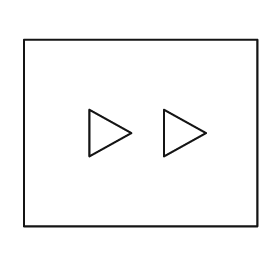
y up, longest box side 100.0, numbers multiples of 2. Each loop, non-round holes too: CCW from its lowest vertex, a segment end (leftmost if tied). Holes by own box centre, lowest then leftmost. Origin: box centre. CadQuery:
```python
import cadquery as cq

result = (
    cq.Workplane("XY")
    .moveTo(-50.0, -40.0)
    .lineTo(50.0, -40.0)
    .lineTo(50.0, 40.0)
    .lineTo(-50.0, 40.0)
    .close()
    .moveTo(-22.0, -10.0)
    .lineTo(-4.0, 0.0)
    .lineTo(-22.0, 10.0)
    .close()
    .moveTo(10.0, -10.0)
    .lineTo(28.0, 0.0)
    .lineTo(10.0, 10.0)
    .close()
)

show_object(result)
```